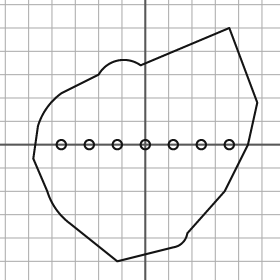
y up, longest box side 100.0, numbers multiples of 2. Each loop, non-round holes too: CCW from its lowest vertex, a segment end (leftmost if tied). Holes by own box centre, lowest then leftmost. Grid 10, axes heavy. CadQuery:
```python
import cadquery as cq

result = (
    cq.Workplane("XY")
    .moveTo(-12.0, -50.0)
    .lineTo(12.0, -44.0)
    .threePointArc((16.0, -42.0), (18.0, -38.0))
    .lineTo(34.0, -20.0)
    .lineTo(44.0, 0.0)
    .lineTo(48.0, 18.0)
    .lineTo(36.0, 50.0)
    .lineTo(-2.0, 34.0)
    .threePointArc((-12.0, 36.0), (-20.0, 30.0))
    .lineTo(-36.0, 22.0)
    .threePointArc((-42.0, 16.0), (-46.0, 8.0))
    .lineTo(-48.0, -6.0)
    .lineTo(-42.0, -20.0)
    .threePointArc((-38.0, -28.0), (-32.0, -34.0))
    .close()
    .moveTo(-36.0, 0.0)
    .circle(2.0)
    .moveTo(-24.0, 0.0)
    .circle(2.0)
    .moveTo(-12.0, 0.0)
    .circle(2.0)
    .moveTo(0.0, 0.0)
    .circle(2.0)
    .moveTo(12.0, 0.0)
    .circle(2.0)
    .moveTo(24.0, 0.0)
    .circle(2.0)
    .moveTo(36.0, 0.0)
    .circle(2.0)
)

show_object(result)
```